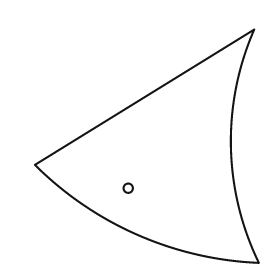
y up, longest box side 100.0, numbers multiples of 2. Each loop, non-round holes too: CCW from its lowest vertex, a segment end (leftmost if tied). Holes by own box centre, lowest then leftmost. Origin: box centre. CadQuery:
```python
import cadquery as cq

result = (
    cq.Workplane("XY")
    .moveTo(48.0, -50.0)
    .threePointArc((36.0, 0.0), (46.0, 50.0))
    .lineTo(-48.0, -8.0)
    .threePointArc((-4.0, -38.0), (48.0, -50.0))
    .close()
    .moveTo(-8.0, -18.0)
    .circle(2.0)
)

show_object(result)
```